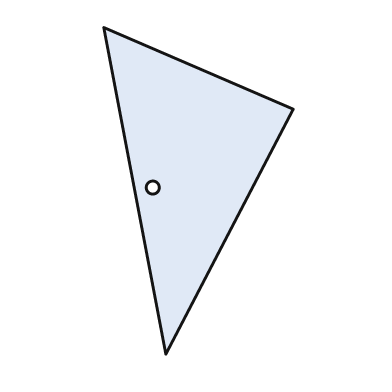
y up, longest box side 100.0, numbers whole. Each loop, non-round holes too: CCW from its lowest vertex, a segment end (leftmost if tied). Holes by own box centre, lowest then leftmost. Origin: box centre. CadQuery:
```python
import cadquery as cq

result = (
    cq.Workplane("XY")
    .moveTo(-10.0, -50.0)
    .lineTo(29.0, 25.0)
    .lineTo(-29.0, 50.0)
    .close()
    .moveTo(-14.0, 1.0)
    .circle(2.0)
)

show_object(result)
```